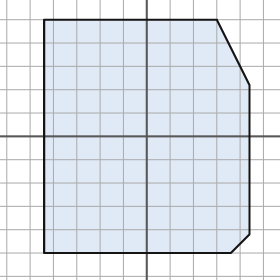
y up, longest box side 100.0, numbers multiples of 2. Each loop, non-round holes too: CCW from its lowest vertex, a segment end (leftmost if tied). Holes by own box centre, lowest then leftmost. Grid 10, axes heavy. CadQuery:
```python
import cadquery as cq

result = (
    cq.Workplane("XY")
    .moveTo(-44.0, -50.0)
    .lineTo(36.0, -50.0)
    .lineTo(44.0, -42.0)
    .lineTo(44.0, 22.0)
    .lineTo(30.0, 50.0)
    .lineTo(-44.0, 50.0)
    .close()
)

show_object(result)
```